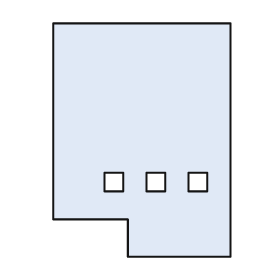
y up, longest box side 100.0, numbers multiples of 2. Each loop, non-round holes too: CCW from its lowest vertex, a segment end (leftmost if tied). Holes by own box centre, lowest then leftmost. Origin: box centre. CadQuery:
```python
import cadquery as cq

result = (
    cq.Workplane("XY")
    .moveTo(-6.0, -50.0)
    .lineTo(38.0, -50.0)
    .lineTo(38.0, 50.0)
    .lineTo(-38.0, 50.0)
    .lineTo(-38.0, -34.0)
    .lineTo(-6.0, -34.0)
    .close()
    .moveTo(-16.0, -22.0)
    .lineTo(-8.0, -22.0)
    .lineTo(-8.0, -14.0)
    .lineTo(-16.0, -14.0)
    .close()
    .moveTo(2.0, -22.0)
    .lineTo(10.0, -22.0)
    .lineTo(10.0, -14.0)
    .lineTo(2.0, -14.0)
    .close()
    .moveTo(20.0, -22.0)
    .lineTo(28.0, -22.0)
    .lineTo(28.0, -14.0)
    .lineTo(20.0, -14.0)
    .close()
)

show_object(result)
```